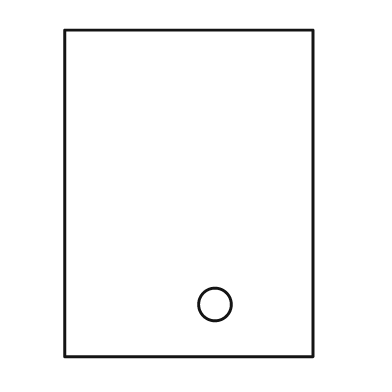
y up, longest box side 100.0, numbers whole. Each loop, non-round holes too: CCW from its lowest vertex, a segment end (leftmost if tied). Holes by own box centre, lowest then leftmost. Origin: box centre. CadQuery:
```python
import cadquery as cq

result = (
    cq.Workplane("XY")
    .moveTo(-38.0, -50.0)
    .lineTo(38.0, -50.0)
    .lineTo(38.0, 50.0)
    .lineTo(-38.0, 50.0)
    .close()
    .moveTo(8.0, -34.0)
    .circle(5.0)
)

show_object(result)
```